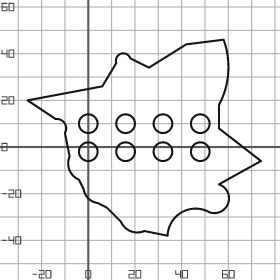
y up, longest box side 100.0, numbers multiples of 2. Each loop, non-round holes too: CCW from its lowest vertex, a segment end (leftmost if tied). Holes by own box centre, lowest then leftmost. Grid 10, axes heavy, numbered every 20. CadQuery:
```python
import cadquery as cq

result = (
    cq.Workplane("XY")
    .moveTo(34.0, -38.0)
    .threePointArc((40.0, -28.0), (52.0, -28.0))
    .threePointArc((60.0, -24.0), (56.0, -16.0))
    .lineTo(74.0, -6.0)
    .lineTo(56.0, 8.0)
    .lineTo(56.0, 18.0)
    .threePointArc((60.0, 32.0), (58.0, 46.0))
    .lineTo(42.0, 44.0)
    .lineTo(26.0, 34.0)
    .lineTo(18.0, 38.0)
    .threePointArc((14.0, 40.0), (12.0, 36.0))
    .lineTo(6.0, 26.0)
    .lineTo(-26.0, 20.0)
    .lineTo(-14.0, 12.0)
    .threePointArc((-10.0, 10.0), (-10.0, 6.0))
    .lineTo(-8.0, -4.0)
    .threePointArc((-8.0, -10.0), (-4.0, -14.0))
    .lineTo(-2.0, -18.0)
    .threePointArc((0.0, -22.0), (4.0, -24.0))
    .lineTo(8.0, -26.0)
    .lineTo(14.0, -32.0)
    .threePointArc((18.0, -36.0), (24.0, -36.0))
    .close()
    .moveTo(0.0, -2.0)
    .circle(4.0)
    .moveTo(16.0, -2.0)
    .circle(4.0)
    .moveTo(32.0, -2.0)
    .circle(4.0)
    .moveTo(48.0, -2.0)
    .circle(4.0)
    .moveTo(0.0, 10.0)
    .circle(4.0)
    .moveTo(16.0, 10.0)
    .circle(4.0)
    .moveTo(32.0, 10.0)
    .circle(4.0)
    .moveTo(48.0, 10.0)
    .circle(4.0)
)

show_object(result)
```